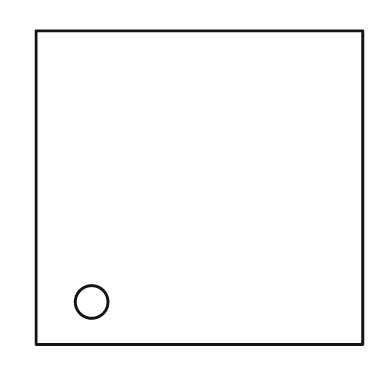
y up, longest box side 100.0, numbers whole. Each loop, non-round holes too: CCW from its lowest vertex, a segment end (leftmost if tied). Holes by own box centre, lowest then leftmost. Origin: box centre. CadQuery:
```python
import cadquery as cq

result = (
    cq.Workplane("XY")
    .moveTo(-50.0, -48.0)
    .lineTo(50.0, -48.0)
    .lineTo(50.0, 48.0)
    .lineTo(-50.0, 48.0)
    .close()
    .moveTo(-33.0, -35.0)
    .circle(5.0)
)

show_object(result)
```